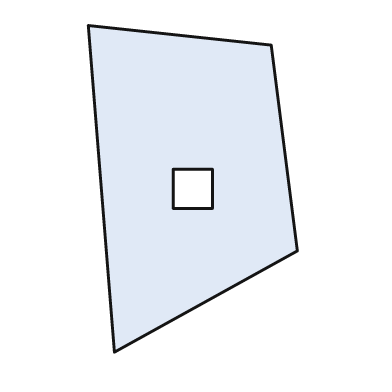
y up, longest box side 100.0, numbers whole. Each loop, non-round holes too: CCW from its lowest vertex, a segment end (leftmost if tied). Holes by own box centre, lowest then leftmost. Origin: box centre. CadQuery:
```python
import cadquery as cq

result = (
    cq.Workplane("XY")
    .moveTo(-24.0, -50.0)
    .lineTo(32.0, -19.0)
    .lineTo(24.0, 44.0)
    .lineTo(-32.0, 50.0)
    .close()
    .moveTo(-6.0, -6.0)
    .lineTo(6.0, -6.0)
    .lineTo(6.0, 6.0)
    .lineTo(-6.0, 6.0)
    .close()
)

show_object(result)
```